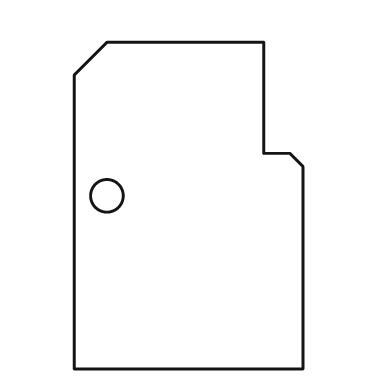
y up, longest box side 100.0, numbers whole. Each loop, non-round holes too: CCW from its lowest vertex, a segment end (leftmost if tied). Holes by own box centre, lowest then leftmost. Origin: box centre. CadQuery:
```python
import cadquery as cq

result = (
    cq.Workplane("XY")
    .moveTo(-35.0, -50.0)
    .lineTo(35.0, -50.0)
    .lineTo(35.0, 12.0)
    .lineTo(31.0, 16.0)
    .lineTo(23.0, 16.0)
    .lineTo(23.0, 50.0)
    .lineTo(-25.0, 50.0)
    .lineTo(-35.0, 40.0)
    .close()
    .moveTo(-25.0, 3.0)
    .circle(5.0)
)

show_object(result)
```